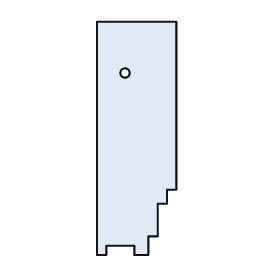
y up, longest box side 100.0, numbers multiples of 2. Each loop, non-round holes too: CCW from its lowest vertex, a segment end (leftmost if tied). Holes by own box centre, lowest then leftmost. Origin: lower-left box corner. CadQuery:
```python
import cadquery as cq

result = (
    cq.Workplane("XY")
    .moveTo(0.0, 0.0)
    .lineTo(4.0, 0.0)
    .lineTo(4.0, 4.0)
    .lineTo(16.0, 4.0)
    .lineTo(16.0, 0.0)
    .lineTo(22.0, 0.0)
    .lineTo(22.0, 8.0)
    .lineTo(26.0, 8.0)
    .lineTo(26.0, 22.0)
    .lineTo(30.0, 22.0)
    .lineTo(30.0, 28.0)
    .lineTo(34.0, 28.0)
    .lineTo(34.0, 100.0)
    .lineTo(0.0, 100.0)
    .close()
    .moveTo(12.0, 78.0)
    .circle(2.0)
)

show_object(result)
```